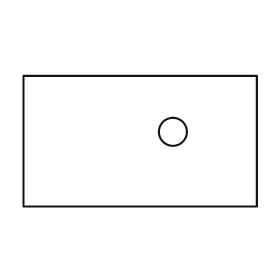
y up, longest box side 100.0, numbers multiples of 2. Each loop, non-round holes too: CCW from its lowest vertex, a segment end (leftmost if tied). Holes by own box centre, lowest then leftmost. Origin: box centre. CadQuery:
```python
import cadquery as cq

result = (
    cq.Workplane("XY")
    .moveTo(-50.0, -28.0)
    .lineTo(50.0, -28.0)
    .lineTo(50.0, 28.0)
    .lineTo(-50.0, 28.0)
    .close()
    .moveTo(14.0, 4.0)
    .circle(6.0)
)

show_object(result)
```